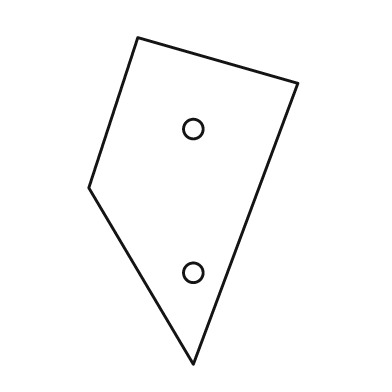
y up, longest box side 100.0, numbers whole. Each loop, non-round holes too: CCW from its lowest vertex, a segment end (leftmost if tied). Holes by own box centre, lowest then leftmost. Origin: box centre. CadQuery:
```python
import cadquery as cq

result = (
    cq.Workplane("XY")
    .moveTo(0.0, -50.0)
    .lineTo(32.0, 36.0)
    .lineTo(-17.0, 50.0)
    .lineTo(-32.0, 4.0)
    .close()
    .moveTo(0.0, -22.0)
    .circle(3.0)
    .moveTo(0.0, 22.0)
    .circle(3.0)
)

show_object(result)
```